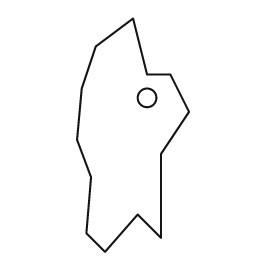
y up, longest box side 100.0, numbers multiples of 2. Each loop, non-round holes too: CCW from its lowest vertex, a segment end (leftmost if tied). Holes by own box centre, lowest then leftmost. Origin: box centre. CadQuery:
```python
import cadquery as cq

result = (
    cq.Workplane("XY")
    .moveTo(-12.0, -50.0)
    .lineTo(2.0, -34.0)
    .lineTo(12.0, -44.0)
    .lineTo(12.0, -8.0)
    .lineTo(24.0, 10.0)
    .lineTo(16.0, 26.0)
    .lineTo(6.0, 26.0)
    .lineTo(0.0, 50.0)
    .lineTo(-16.0, 38.0)
    .lineTo(-22.0, 20.0)
    .lineTo(-24.0, -2.0)
    .lineTo(-18.0, -18.0)
    .lineTo(-20.0, -42.0)
    .close()
    .moveTo(6.0, 16.0)
    .circle(4.0)
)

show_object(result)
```